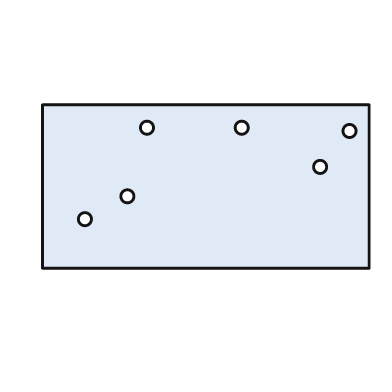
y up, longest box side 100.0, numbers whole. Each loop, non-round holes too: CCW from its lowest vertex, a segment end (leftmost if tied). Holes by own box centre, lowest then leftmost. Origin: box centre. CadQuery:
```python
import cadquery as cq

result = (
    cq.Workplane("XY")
    .moveTo(-50.0, -25.0)
    .lineTo(50.0, -25.0)
    .lineTo(50.0, 25.0)
    .lineTo(-50.0, 25.0)
    .close()
    .moveTo(-37.0, -10.0)
    .circle(2.0)
    .moveTo(-24.0, -3.0)
    .circle(2.0)
    .moveTo(35.0, 6.0)
    .circle(2.0)
    .moveTo(44.0, 17.0)
    .circle(2.0)
    .moveTo(-18.0, 18.0)
    .circle(2.0)
    .moveTo(11.0, 18.0)
    .circle(2.0)
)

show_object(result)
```